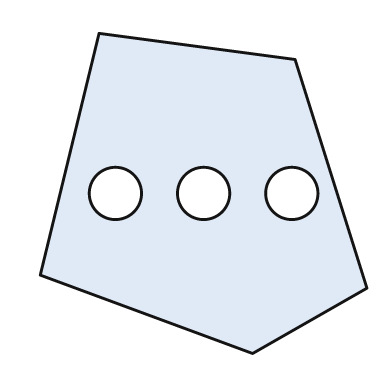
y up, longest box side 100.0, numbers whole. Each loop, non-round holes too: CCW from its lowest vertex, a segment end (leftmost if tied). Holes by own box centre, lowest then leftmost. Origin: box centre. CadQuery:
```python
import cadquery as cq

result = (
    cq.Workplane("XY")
    .moveTo(15.0, -49.0)
    .lineTo(50.0, -29.0)
    .lineTo(28.0, 41.0)
    .lineTo(-32.0, 49.0)
    .lineTo(-50.0, -25.0)
    .close()
    .moveTo(-27.0, 0.0)
    .circle(8.0)
    .moveTo(0.0, 0.0)
    .circle(8.0)
    .moveTo(27.0, 0.0)
    .circle(8.0)
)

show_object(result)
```